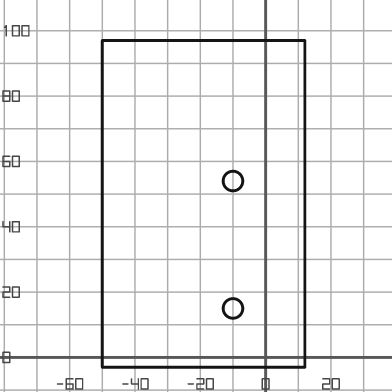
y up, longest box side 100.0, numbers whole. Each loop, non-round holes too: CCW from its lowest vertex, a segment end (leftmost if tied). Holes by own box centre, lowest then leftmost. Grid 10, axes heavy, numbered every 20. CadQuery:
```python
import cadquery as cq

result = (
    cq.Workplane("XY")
    .moveTo(-50.0, -3.0)
    .lineTo(12.0, -3.0)
    .lineTo(12.0, 97.0)
    .lineTo(-50.0, 97.0)
    .close()
    .moveTo(-10.0, 15.0)
    .circle(3.0)
    .moveTo(-10.0, 54.0)
    .circle(3.0)
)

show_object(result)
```